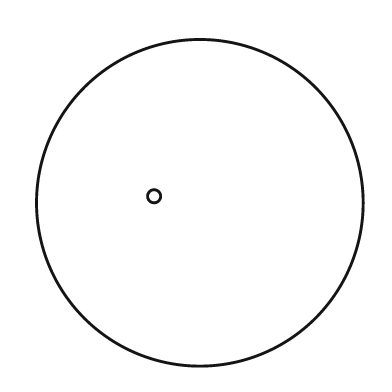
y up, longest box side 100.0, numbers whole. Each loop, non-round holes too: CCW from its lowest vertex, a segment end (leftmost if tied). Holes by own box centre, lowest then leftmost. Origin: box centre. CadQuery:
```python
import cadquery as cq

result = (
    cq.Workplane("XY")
    .moveTo(0.0, 0.0)
    .circle(50.0)
    .moveTo(-14.0, 2.0)
    .circle(2.0)
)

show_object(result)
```